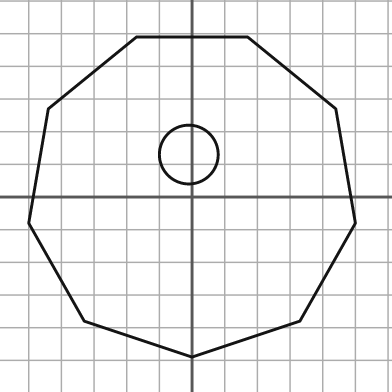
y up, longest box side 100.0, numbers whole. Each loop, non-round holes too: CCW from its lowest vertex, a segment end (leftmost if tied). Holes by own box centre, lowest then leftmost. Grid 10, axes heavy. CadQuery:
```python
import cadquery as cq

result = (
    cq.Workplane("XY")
    .moveTo(0.0, -49.0)
    .lineTo(33.0, -38.0)
    .lineTo(50.0, -8.0)
    .lineTo(44.0, 27.0)
    .lineTo(17.0, 49.0)
    .lineTo(-17.0, 49.0)
    .lineTo(-44.0, 27.0)
    .lineTo(-50.0, -8.0)
    .lineTo(-33.0, -38.0)
    .close()
    .moveTo(-1.0, 13.0)
    .circle(9.0)
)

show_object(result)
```